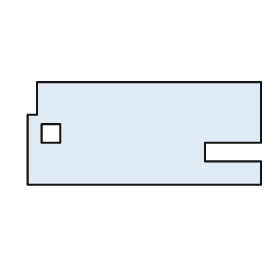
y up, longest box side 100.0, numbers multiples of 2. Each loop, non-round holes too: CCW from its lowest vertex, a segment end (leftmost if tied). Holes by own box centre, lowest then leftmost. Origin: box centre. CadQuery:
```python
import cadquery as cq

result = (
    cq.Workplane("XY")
    .moveTo(-50.0, -22.0)
    .lineTo(50.0, -22.0)
    .lineTo(50.0, -12.0)
    .lineTo(26.0, -12.0)
    .lineTo(26.0, -4.0)
    .lineTo(50.0, -4.0)
    .lineTo(50.0, 22.0)
    .lineTo(-46.0, 22.0)
    .lineTo(-46.0, 8.0)
    .lineTo(-50.0, 8.0)
    .close()
    .moveTo(-44.0, -4.0)
    .lineTo(-36.0, -4.0)
    .lineTo(-36.0, 4.0)
    .lineTo(-44.0, 4.0)
    .close()
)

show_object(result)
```